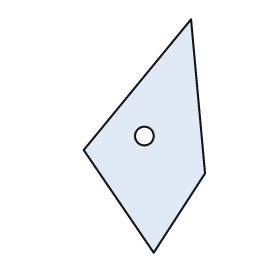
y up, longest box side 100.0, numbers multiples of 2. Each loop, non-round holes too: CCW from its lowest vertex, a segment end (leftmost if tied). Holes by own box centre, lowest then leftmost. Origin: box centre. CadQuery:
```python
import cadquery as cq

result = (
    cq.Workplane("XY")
    .moveTo(4.0, -50.0)
    .lineTo(26.0, -16.0)
    .lineTo(20.0, 50.0)
    .lineTo(-26.0, -6.0)
    .close()
    .moveTo(0.0, 0.0)
    .circle(4.0)
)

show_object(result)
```